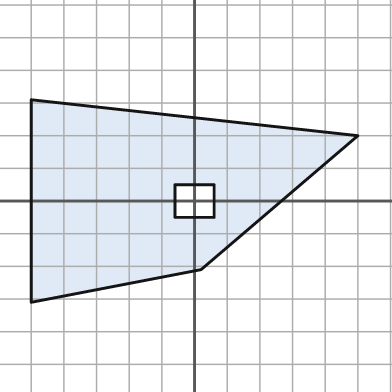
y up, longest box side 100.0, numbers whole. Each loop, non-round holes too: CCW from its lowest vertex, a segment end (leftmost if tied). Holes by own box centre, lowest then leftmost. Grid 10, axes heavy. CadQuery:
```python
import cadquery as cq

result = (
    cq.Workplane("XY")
    .moveTo(-50.0, -31.0)
    .lineTo(2.0, -21.0)
    .lineTo(50.0, 20.0)
    .lineTo(-50.0, 31.0)
    .close()
    .moveTo(-6.0, -5.0)
    .lineTo(6.0, -5.0)
    .lineTo(6.0, 5.0)
    .lineTo(-6.0, 5.0)
    .close()
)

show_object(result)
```